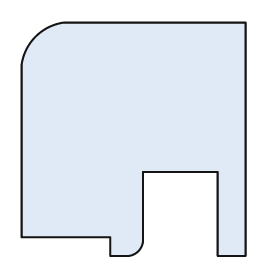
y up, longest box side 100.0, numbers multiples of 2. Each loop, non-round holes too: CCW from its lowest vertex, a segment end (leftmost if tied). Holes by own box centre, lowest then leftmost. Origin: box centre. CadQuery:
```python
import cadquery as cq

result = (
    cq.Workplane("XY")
    .moveTo(-10.0, -50.0)
    .lineTo(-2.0, -50.0)
    .threePointArc((2.0, -48.0), (4.0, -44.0))
    .lineTo(4.0, -14.0)
    .lineTo(36.0, -14.0)
    .lineTo(36.0, -50.0)
    .lineTo(48.0, -50.0)
    .lineTo(48.0, 50.0)
    .lineTo(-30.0, 50.0)
    .threePointArc((-42.0, 44.0), (-48.0, 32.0))
    .lineTo(-48.0, -42.0)
    .lineTo(-10.0, -42.0)
    .close()
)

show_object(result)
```